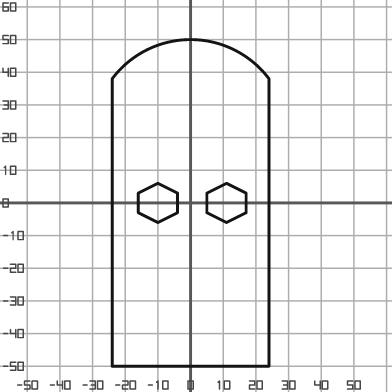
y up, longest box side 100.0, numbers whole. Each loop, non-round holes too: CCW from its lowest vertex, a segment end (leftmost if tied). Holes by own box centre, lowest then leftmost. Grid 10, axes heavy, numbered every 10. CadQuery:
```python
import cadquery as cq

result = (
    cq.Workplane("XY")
    .moveTo(-24.0, -50.0)
    .lineTo(24.0, -50.0)
    .lineTo(24.0, 38.0)
    .threePointArc((0.0, 50.0), (-24.0, 38.0))
    .close()
    .moveTo(-10.0, -6.0)
    .lineTo(-4.0, -3.0)
    .lineTo(-4.0, 3.0)
    .lineTo(-10.0, 6.0)
    .lineTo(-16.0, 3.0)
    .lineTo(-16.0, -3.0)
    .close()
    .moveTo(11.0, -6.0)
    .lineTo(17.0, -3.0)
    .lineTo(17.0, 3.0)
    .lineTo(11.0, 6.0)
    .lineTo(5.0, 3.0)
    .lineTo(5.0, -3.0)
    .close()
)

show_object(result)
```